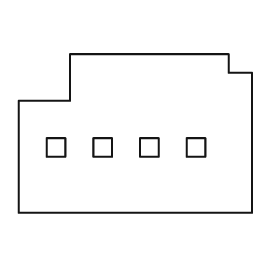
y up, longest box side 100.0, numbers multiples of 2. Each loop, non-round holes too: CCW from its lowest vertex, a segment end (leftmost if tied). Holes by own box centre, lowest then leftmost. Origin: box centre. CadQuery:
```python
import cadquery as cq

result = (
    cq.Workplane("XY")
    .moveTo(-50.0, -34.0)
    .lineTo(50.0, -34.0)
    .lineTo(50.0, 26.0)
    .lineTo(40.0, 26.0)
    .lineTo(40.0, 34.0)
    .lineTo(-28.0, 34.0)
    .lineTo(-28.0, 14.0)
    .lineTo(-50.0, 14.0)
    .close()
    .moveTo(-38.0, -10.0)
    .lineTo(-30.0, -10.0)
    .lineTo(-30.0, -2.0)
    .lineTo(-38.0, -2.0)
    .close()
    .moveTo(-18.0, -10.0)
    .lineTo(-10.0, -10.0)
    .lineTo(-10.0, -2.0)
    .lineTo(-18.0, -2.0)
    .close()
    .moveTo(2.0, -10.0)
    .lineTo(10.0, -10.0)
    .lineTo(10.0, -2.0)
    .lineTo(2.0, -2.0)
    .close()
    .moveTo(22.0, -10.0)
    .lineTo(30.0, -10.0)
    .lineTo(30.0, -2.0)
    .lineTo(22.0, -2.0)
    .close()
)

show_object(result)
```